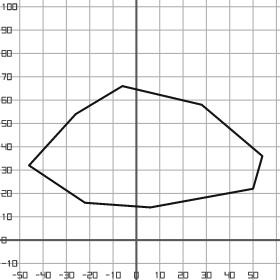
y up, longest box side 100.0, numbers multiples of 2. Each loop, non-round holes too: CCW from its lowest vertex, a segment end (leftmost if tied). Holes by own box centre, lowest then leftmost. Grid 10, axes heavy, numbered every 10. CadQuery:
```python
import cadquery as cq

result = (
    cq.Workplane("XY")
    .moveTo(6.0, 14.0)
    .lineTo(50.0, 22.0)
    .lineTo(54.0, 36.0)
    .lineTo(28.0, 58.0)
    .lineTo(-6.0, 66.0)
    .lineTo(-26.0, 54.0)
    .lineTo(-46.0, 32.0)
    .lineTo(-22.0, 16.0)
    .close()
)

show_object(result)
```